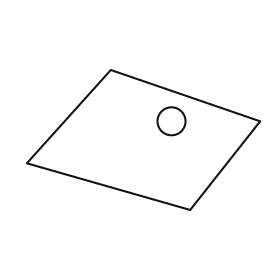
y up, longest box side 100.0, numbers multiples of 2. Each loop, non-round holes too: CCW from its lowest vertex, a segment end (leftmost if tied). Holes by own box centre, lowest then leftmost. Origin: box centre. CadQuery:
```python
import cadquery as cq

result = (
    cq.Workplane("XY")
    .moveTo(20.0, -30.0)
    .lineTo(50.0, 8.0)
    .lineTo(-14.0, 30.0)
    .lineTo(-50.0, -10.0)
    .close()
    .moveTo(12.0, 8.0)
    .circle(6.0)
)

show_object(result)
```